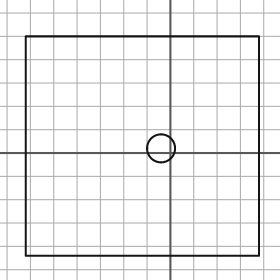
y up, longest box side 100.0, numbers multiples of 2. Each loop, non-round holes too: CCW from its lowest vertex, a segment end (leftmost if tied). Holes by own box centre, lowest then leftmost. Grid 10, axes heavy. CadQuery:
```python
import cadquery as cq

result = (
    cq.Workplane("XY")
    .moveTo(-62.0, -44.0)
    .lineTo(38.0, -44.0)
    .lineTo(38.0, 50.0)
    .lineTo(-62.0, 50.0)
    .close()
    .moveTo(-4.0, 2.0)
    .circle(6.0)
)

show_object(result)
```